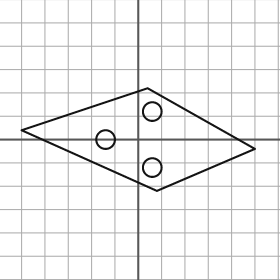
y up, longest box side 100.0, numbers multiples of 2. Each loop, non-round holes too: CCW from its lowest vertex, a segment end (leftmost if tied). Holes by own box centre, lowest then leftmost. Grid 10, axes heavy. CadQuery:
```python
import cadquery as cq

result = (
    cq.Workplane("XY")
    .moveTo(8.0, -22.0)
    .lineTo(50.0, -4.0)
    .lineTo(4.0, 22.0)
    .lineTo(-50.0, 4.0)
    .close()
    .moveTo(6.0, -12.0)
    .circle(4.0)
    .moveTo(-14.0, 0.0)
    .circle(4.0)
    .moveTo(6.0, 12.0)
    .circle(4.0)
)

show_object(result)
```